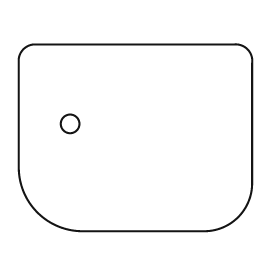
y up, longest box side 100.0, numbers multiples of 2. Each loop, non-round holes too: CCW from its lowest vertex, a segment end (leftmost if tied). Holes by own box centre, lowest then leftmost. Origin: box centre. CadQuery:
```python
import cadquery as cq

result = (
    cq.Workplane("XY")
    .moveTo(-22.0, -40.0)
    .lineTo(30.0, -40.0)
    .threePointArc((44.0, -34.0), (50.0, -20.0))
    .lineTo(50.0, 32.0)
    .threePointArc((48.0, 38.0), (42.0, 40.0))
    .lineTo(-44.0, 40.0)
    .threePointArc((-48.0, 38.0), (-50.0, 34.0))
    .lineTo(-50.0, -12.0)
    .threePointArc((-42.0, -32.0), (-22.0, -40.0))
    .close()
    .moveTo(-28.0, 6.0)
    .circle(4.0)
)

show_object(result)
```